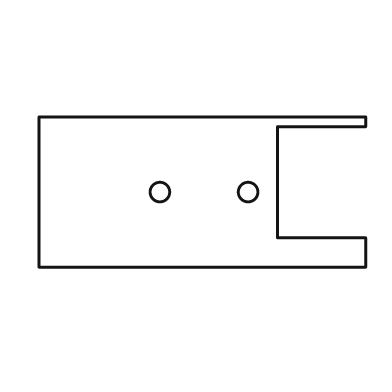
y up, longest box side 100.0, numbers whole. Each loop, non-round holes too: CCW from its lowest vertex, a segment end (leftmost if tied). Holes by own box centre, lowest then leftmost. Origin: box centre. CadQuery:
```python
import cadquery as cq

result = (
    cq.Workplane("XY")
    .moveTo(-50.0, -23.0)
    .lineTo(50.0, -23.0)
    .lineTo(50.0, -14.0)
    .lineTo(23.0, -14.0)
    .lineTo(23.0, 20.0)
    .lineTo(50.0, 20.0)
    .lineTo(50.0, 23.0)
    .lineTo(-50.0, 23.0)
    .close()
    .moveTo(-13.0, 0.0)
    .circle(3.0)
    .moveTo(14.0, 0.0)
    .circle(3.0)
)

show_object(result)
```